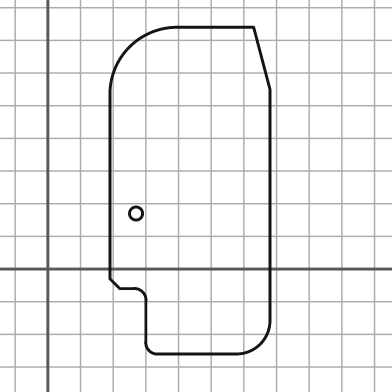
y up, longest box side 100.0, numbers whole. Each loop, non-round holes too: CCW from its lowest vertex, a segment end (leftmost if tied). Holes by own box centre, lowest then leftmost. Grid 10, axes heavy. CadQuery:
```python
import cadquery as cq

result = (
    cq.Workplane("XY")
    .moveTo(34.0, -26.0)
    .lineTo(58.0, -26.0)
    .threePointArc((65.0, -23.0), (68.0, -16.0))
    .lineTo(68.0, 55.0)
    .lineTo(63.0, 74.0)
    .lineTo(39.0, 74.0)
    .threePointArc((25.0, 68.0), (19.0, 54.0))
    .lineTo(19.0, -3.0)
    .lineTo(22.0, -6.0)
    .lineTo(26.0, -6.0)
    .threePointArc((29.0, -7.0), (30.0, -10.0))
    .lineTo(30.0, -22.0)
    .threePointArc((31.0, -25.0), (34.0, -26.0))
    .close()
    .moveTo(27.0, 17.0)
    .circle(2.0)
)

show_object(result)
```